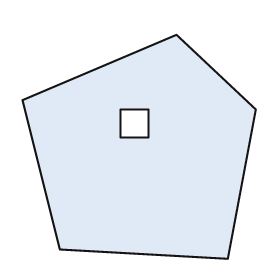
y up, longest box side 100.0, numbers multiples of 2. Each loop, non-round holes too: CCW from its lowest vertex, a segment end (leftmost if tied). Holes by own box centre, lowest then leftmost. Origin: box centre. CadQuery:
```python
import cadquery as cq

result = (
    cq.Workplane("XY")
    .moveTo(38.0, -48.0)
    .lineTo(50.0, 16.0)
    .lineTo(16.0, 48.0)
    .lineTo(-50.0, 20.0)
    .lineTo(-34.0, -44.0)
    .close()
    .moveTo(-8.0, 4.0)
    .lineTo(4.0, 4.0)
    .lineTo(4.0, 16.0)
    .lineTo(-8.0, 16.0)
    .close()
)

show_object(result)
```